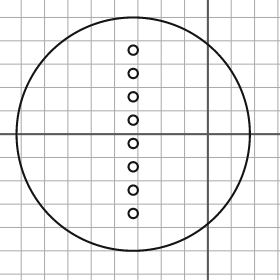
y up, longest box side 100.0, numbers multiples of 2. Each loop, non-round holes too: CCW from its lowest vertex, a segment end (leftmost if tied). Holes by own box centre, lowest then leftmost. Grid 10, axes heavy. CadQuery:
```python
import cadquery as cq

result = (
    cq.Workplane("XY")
    .moveTo(-32.0, 0.0)
    .circle(50.0)
    .moveTo(-32.0, -34.0)
    .circle(2.0)
    .moveTo(-32.0, -24.0)
    .circle(2.0)
    .moveTo(-32.0, -14.0)
    .circle(2.0)
    .moveTo(-32.0, -4.0)
    .circle(2.0)
    .moveTo(-32.0, 6.0)
    .circle(2.0)
    .moveTo(-32.0, 16.0)
    .circle(2.0)
    .moveTo(-32.0, 26.0)
    .circle(2.0)
    .moveTo(-32.0, 36.0)
    .circle(2.0)
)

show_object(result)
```